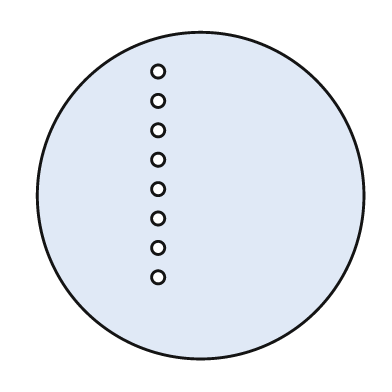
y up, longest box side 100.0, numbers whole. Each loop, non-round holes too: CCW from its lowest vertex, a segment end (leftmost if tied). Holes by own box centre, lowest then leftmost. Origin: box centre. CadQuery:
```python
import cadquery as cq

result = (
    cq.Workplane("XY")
    .moveTo(0.0, 0.0)
    .circle(50.0)
    .moveTo(-13.0, -25.0)
    .circle(2.0)
    .moveTo(-13.0, -16.0)
    .circle(2.0)
    .moveTo(-13.0, -7.0)
    .circle(2.0)
    .moveTo(-13.0, 2.0)
    .circle(2.0)
    .moveTo(-13.0, 11.0)
    .circle(2.0)
    .moveTo(-13.0, 20.0)
    .circle(2.0)
    .moveTo(-13.0, 29.0)
    .circle(2.0)
    .moveTo(-13.0, 38.0)
    .circle(2.0)
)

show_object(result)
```